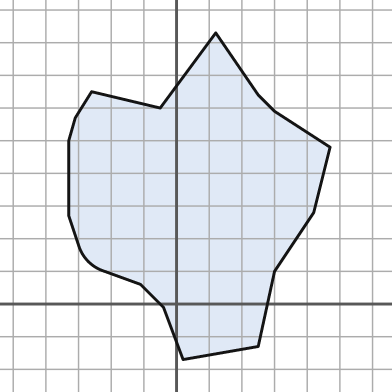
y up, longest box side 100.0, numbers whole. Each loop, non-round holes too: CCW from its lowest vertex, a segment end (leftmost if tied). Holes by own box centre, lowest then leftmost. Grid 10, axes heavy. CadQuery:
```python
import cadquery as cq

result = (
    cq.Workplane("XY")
    .moveTo(2.0, -17.0)
    .lineTo(25.0, -13.0)
    .lineTo(30.0, 10.0)
    .lineTo(42.0, 28.0)
    .lineTo(47.0, 48.0)
    .lineTo(30.0, 59.0)
    .lineTo(25.0, 64.0)
    .lineTo(12.0, 83.0)
    .lineTo(-5.0, 60.0)
    .lineTo(-26.0, 65.0)
    .lineTo(-31.0, 57.0)
    .lineTo(-33.0, 50.0)
    .lineTo(-33.0, 27.0)
    .lineTo(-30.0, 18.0)
    .threePointArc((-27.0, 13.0), (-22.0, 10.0))
    .lineTo(-11.0, 6.0)
    .lineTo(-4.0, -1.0)
    .close()
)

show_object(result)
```